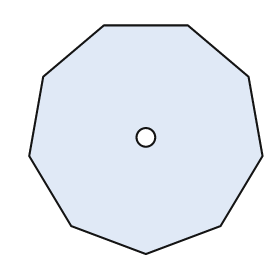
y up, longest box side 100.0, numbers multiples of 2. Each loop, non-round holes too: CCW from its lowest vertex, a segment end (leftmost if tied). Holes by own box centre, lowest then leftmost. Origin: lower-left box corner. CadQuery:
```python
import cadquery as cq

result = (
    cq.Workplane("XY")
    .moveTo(50.0, 0.0)
    .lineTo(82.0, 12.0)
    .lineTo(100.0, 42.0)
    .lineTo(94.0, 76.0)
    .lineTo(68.0, 98.0)
    .lineTo(32.0, 98.0)
    .lineTo(6.0, 76.0)
    .lineTo(0.0, 42.0)
    .lineTo(18.0, 12.0)
    .close()
    .moveTo(50.0, 50.0)
    .circle(4.0)
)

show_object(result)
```